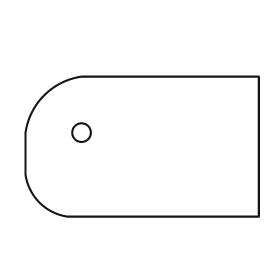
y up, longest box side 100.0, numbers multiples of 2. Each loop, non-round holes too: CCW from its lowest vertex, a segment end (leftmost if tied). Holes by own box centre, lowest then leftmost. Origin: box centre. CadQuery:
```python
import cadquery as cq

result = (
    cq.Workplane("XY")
    .moveTo(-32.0, -30.0)
    .lineTo(50.0, -30.0)
    .lineTo(50.0, 30.0)
    .lineTo(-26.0, 30.0)
    .threePointArc((-42.0, 22.0), (-50.0, 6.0))
    .lineTo(-50.0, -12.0)
    .threePointArc((-44.0, -24.0), (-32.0, -30.0))
    .close()
    .moveTo(-26.0, 6.0)
    .circle(4.0)
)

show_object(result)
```